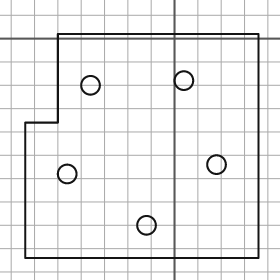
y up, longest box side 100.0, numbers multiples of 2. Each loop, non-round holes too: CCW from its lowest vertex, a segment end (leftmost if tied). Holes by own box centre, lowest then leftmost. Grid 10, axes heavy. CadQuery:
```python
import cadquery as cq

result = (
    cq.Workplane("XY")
    .moveTo(-64.0, -94.0)
    .lineTo(36.0, -94.0)
    .lineTo(36.0, 2.0)
    .lineTo(-50.0, 2.0)
    .lineTo(-50.0, -36.0)
    .lineTo(-64.0, -36.0)
    .close()
    .moveTo(-12.0, -80.0)
    .circle(4.0)
    .moveTo(-46.0, -58.0)
    .circle(4.0)
    .moveTo(18.0, -54.0)
    .circle(4.0)
    .moveTo(-36.0, -20.0)
    .circle(4.0)
    .moveTo(4.0, -18.0)
    .circle(4.0)
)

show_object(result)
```